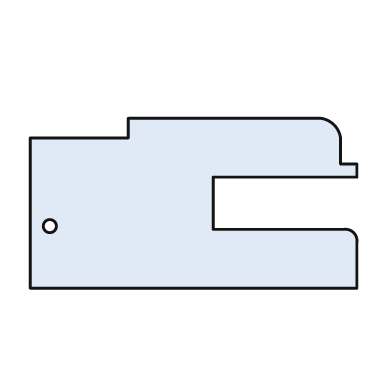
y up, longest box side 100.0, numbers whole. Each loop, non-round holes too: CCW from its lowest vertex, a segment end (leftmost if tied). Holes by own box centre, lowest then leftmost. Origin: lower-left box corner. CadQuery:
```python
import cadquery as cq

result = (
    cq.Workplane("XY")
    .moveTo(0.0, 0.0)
    .lineTo(100.0, 0.0)
    .lineTo(100.0, 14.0)
    .threePointArc((99.0, 17.0), (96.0, 18.0))
    .lineTo(56.0, 18.0)
    .lineTo(56.0, 34.0)
    .lineTo(100.0, 34.0)
    .lineTo(100.0, 38.0)
    .lineTo(95.0, 38.0)
    .lineTo(95.0, 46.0)
    .threePointArc((93.0, 50.0), (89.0, 52.0))
    .lineTo(30.0, 52.0)
    .lineTo(30.0, 46.0)
    .lineTo(0.0, 46.0)
    .close()
    .moveTo(6.0, 19.0)
    .circle(2.0)
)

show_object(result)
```